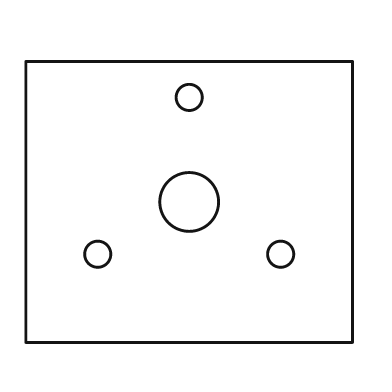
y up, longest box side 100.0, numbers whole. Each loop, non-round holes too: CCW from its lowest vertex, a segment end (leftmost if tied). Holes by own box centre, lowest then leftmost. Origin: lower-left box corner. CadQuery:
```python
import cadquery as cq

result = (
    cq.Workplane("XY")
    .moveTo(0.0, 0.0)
    .lineTo(100.0, 0.0)
    .lineTo(100.0, 86.0)
    .lineTo(0.0, 86.0)
    .close()
    .moveTo(22.0, 27.0)
    .circle(4.0)
    .moveTo(78.0, 27.0)
    .circle(4.0)
    .moveTo(50.0, 43.0)
    .circle(9.0)
    .moveTo(50.0, 75.0)
    .circle(4.0)
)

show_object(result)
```